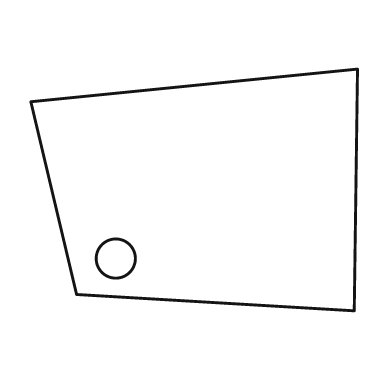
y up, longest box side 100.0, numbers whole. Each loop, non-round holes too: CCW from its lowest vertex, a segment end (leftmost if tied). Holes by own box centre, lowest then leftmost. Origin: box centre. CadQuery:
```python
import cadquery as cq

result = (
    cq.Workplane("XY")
    .moveTo(49.0, -37.0)
    .lineTo(50.0, 37.0)
    .lineTo(-50.0, 27.0)
    .lineTo(-36.0, -32.0)
    .close()
    .moveTo(-24.0, -21.0)
    .circle(6.0)
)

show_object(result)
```